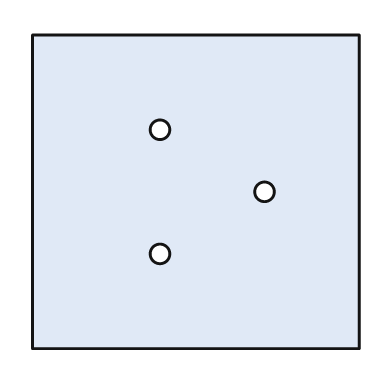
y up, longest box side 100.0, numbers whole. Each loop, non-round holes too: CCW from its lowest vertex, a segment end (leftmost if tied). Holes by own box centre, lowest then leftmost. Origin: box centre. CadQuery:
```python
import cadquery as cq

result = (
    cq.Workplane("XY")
    .moveTo(-50.0, -48.0)
    .lineTo(50.0, -48.0)
    .lineTo(50.0, 48.0)
    .lineTo(-50.0, 48.0)
    .close()
    .moveTo(-11.0, -19.0)
    .circle(3.0)
    .moveTo(21.0, 0.0)
    .circle(3.0)
    .moveTo(-11.0, 19.0)
    .circle(3.0)
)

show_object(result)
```